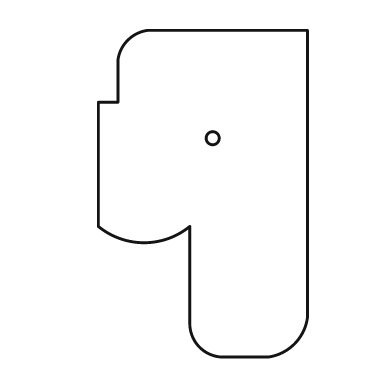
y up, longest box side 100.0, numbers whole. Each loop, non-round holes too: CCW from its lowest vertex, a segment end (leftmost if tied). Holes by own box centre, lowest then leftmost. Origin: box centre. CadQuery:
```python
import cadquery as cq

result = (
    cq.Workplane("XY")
    .moveTo(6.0, -50.0)
    .lineTo(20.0, -50.0)
    .threePointArc((28.0, -46.0), (32.0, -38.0))
    .lineTo(32.0, 50.0)
    .lineTo(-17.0, 50.0)
    .threePointArc((-23.0, 47.0), (-26.0, 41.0))
    .lineTo(-26.0, 28.0)
    .lineTo(-32.0, 28.0)
    .lineTo(-32.0, -10.0)
    .threePointArc((-18.0, -15.0), (-4.0, -10.0))
    .lineTo(-4.0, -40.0)
    .threePointArc((-1.0, -47.0), (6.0, -50.0))
    .close()
    .moveTo(3.0, 17.0)
    .circle(2.0)
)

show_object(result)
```